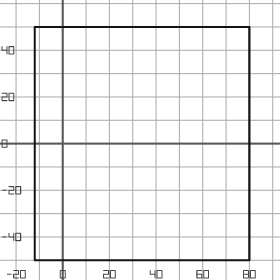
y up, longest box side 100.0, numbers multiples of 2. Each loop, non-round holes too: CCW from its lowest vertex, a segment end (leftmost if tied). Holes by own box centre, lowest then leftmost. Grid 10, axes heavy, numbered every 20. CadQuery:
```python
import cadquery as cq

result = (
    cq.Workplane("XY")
    .moveTo(-12.0, -50.0)
    .lineTo(80.0, -50.0)
    .lineTo(80.0, 50.0)
    .lineTo(-12.0, 50.0)
    .close()
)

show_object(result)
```